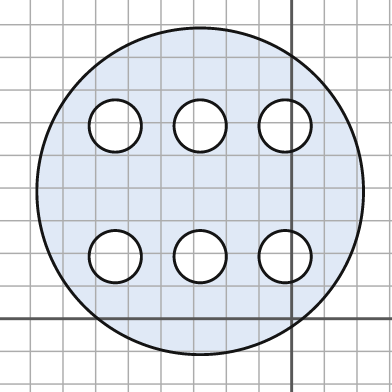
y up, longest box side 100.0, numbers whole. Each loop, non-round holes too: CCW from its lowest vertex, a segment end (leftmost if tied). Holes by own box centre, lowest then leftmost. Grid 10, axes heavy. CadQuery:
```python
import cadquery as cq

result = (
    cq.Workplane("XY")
    .moveTo(-28.0, 39.0)
    .circle(50.0)
    .moveTo(-54.0, 19.0)
    .circle(8.0)
    .moveTo(-28.0, 19.0)
    .circle(8.0)
    .moveTo(-2.0, 19.0)
    .circle(8.0)
    .moveTo(-54.0, 59.0)
    .circle(8.0)
    .moveTo(-28.0, 59.0)
    .circle(8.0)
    .moveTo(-2.0, 59.0)
    .circle(8.0)
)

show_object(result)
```